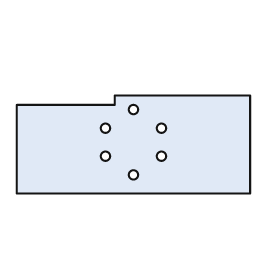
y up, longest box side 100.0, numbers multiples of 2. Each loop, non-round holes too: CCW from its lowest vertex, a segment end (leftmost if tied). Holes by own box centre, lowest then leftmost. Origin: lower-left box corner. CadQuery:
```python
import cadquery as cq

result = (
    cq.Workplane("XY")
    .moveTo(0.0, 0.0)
    .lineTo(100.0, 0.0)
    .lineTo(100.0, 42.0)
    .lineTo(42.0, 42.0)
    .lineTo(42.0, 38.0)
    .lineTo(0.0, 38.0)
    .close()
    .moveTo(50.0, 8.0)
    .circle(2.0)
    .moveTo(38.0, 16.0)
    .circle(2.0)
    .moveTo(62.0, 16.0)
    .circle(2.0)
    .moveTo(38.0, 28.0)
    .circle(2.0)
    .moveTo(62.0, 28.0)
    .circle(2.0)
    .moveTo(50.0, 36.0)
    .circle(2.0)
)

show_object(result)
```